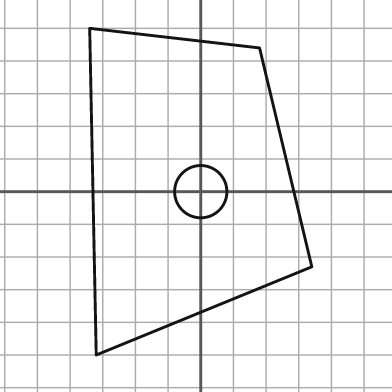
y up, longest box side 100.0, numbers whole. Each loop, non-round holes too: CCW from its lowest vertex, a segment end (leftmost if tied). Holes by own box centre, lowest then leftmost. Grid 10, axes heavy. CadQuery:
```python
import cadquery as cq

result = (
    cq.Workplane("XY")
    .moveTo(-32.0, -50.0)
    .lineTo(34.0, -23.0)
    .lineTo(18.0, 44.0)
    .lineTo(-34.0, 50.0)
    .close()
    .moveTo(0.0, 0.0)
    .circle(8.0)
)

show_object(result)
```